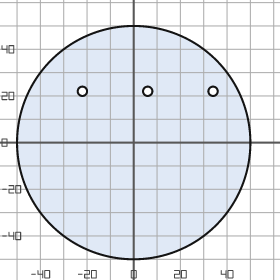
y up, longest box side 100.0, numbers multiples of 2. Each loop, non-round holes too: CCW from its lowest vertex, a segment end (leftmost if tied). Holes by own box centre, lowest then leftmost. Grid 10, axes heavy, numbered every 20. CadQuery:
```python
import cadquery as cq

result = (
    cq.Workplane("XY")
    .moveTo(0.0, 0.0)
    .circle(50.0)
    .moveTo(-22.0, 22.0)
    .circle(2.0)
    .moveTo(6.0, 22.0)
    .circle(2.0)
    .moveTo(34.0, 22.0)
    .circle(2.0)
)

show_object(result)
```